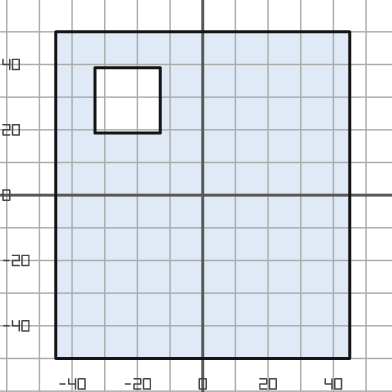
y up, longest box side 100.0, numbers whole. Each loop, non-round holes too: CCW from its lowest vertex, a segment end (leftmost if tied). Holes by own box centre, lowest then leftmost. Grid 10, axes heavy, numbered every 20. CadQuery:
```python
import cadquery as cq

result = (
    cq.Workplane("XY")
    .moveTo(-45.0, -50.0)
    .lineTo(45.0, -50.0)
    .lineTo(45.0, 50.0)
    .lineTo(-45.0, 50.0)
    .close()
    .moveTo(-33.0, 19.0)
    .lineTo(-13.0, 19.0)
    .lineTo(-13.0, 39.0)
    .lineTo(-33.0, 39.0)
    .close()
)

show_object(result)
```